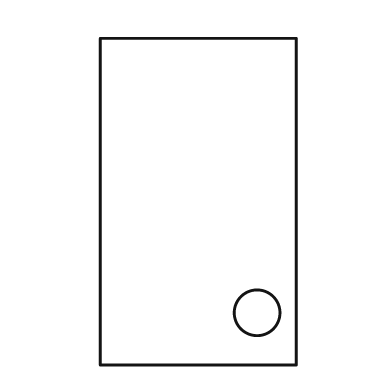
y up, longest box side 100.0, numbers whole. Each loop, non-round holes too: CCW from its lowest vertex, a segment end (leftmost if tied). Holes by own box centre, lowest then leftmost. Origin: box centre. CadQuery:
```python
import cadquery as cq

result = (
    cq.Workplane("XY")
    .moveTo(-30.0, -50.0)
    .lineTo(30.0, -50.0)
    .lineTo(30.0, 50.0)
    .lineTo(-30.0, 50.0)
    .close()
    .moveTo(18.0, -34.0)
    .circle(7.0)
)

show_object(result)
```